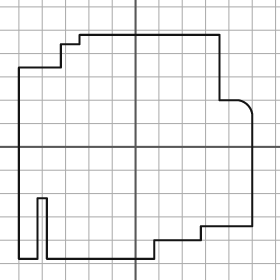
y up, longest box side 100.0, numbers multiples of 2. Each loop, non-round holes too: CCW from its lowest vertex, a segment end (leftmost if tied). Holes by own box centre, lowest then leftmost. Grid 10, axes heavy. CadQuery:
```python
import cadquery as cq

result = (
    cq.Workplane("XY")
    .moveTo(-50.0, -48.0)
    .lineTo(-42.0, -48.0)
    .lineTo(-42.0, -22.0)
    .lineTo(-38.0, -22.0)
    .lineTo(-38.0, -48.0)
    .lineTo(8.0, -48.0)
    .lineTo(8.0, -40.0)
    .lineTo(28.0, -40.0)
    .lineTo(28.0, -34.0)
    .lineTo(50.0, -34.0)
    .lineTo(50.0, 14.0)
    .threePointArc((48.0, 18.0), (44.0, 20.0))
    .lineTo(36.0, 20.0)
    .lineTo(36.0, 48.0)
    .lineTo(-24.0, 48.0)
    .lineTo(-24.0, 44.0)
    .lineTo(-32.0, 44.0)
    .lineTo(-32.0, 34.0)
    .lineTo(-50.0, 34.0)
    .close()
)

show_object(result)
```